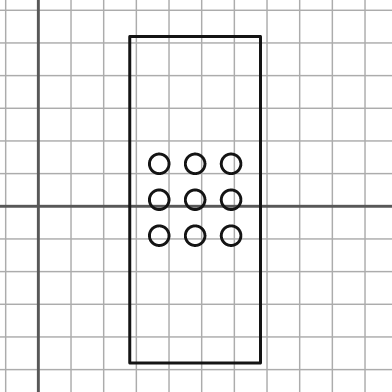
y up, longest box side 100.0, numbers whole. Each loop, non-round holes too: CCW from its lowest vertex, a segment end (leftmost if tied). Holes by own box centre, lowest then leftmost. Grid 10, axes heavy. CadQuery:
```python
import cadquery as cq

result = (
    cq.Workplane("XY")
    .moveTo(28.0, -48.0)
    .lineTo(68.0, -48.0)
    .lineTo(68.0, 52.0)
    .lineTo(28.0, 52.0)
    .close()
    .moveTo(37.0, -9.0)
    .circle(3.0)
    .moveTo(48.0, -9.0)
    .circle(3.0)
    .moveTo(59.0, -9.0)
    .circle(3.0)
    .moveTo(37.0, 2.0)
    .circle(3.0)
    .moveTo(48.0, 2.0)
    .circle(3.0)
    .moveTo(59.0, 2.0)
    .circle(3.0)
    .moveTo(37.0, 13.0)
    .circle(3.0)
    .moveTo(48.0, 13.0)
    .circle(3.0)
    .moveTo(59.0, 13.0)
    .circle(3.0)
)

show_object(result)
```